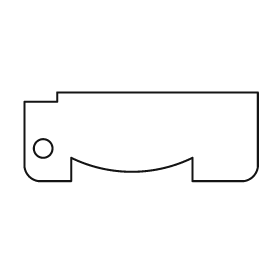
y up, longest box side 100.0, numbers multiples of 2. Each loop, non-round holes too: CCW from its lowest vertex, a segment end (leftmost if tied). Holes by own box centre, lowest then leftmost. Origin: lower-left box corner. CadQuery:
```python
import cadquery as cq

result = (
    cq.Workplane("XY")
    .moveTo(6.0, 0.0)
    .lineTo(20.0, 0.0)
    .lineTo(20.0, 10.0)
    .threePointArc((46.0, 4.0), (72.0, 10.0))
    .lineTo(72.0, 0.0)
    .lineTo(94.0, 0.0)
    .threePointArc((98.0, 2.0), (100.0, 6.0))
    .lineTo(100.0, 38.0)
    .lineTo(14.0, 38.0)
    .lineTo(14.0, 34.0)
    .lineTo(0.0, 34.0)
    .lineTo(0.0, 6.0)
    .threePointArc((2.0, 2.0), (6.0, 0.0))
    .close()
    .moveTo(8.0, 14.0)
    .circle(4.0)
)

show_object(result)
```